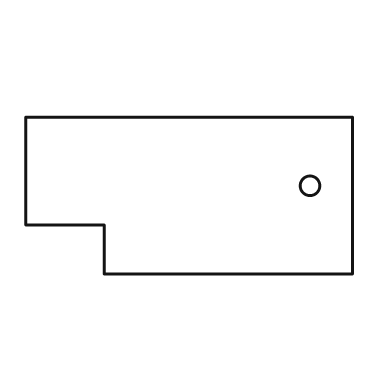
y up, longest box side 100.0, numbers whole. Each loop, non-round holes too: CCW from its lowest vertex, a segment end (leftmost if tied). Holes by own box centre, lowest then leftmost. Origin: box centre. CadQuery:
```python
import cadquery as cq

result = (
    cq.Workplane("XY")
    .moveTo(-26.0, -24.0)
    .lineTo(50.0, -24.0)
    .lineTo(50.0, 24.0)
    .lineTo(-50.0, 24.0)
    .lineTo(-50.0, -9.0)
    .lineTo(-26.0, -9.0)
    .close()
    .moveTo(37.0, 3.0)
    .circle(3.0)
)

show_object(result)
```